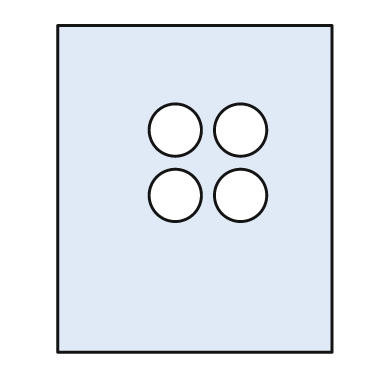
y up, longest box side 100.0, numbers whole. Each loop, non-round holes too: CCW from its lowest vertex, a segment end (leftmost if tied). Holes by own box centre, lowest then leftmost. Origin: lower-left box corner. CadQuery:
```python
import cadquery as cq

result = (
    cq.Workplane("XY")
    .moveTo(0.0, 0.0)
    .lineTo(84.0, 0.0)
    .lineTo(84.0, 100.0)
    .lineTo(0.0, 100.0)
    .close()
    .moveTo(36.0, 48.0)
    .circle(8.0)
    .moveTo(56.0, 48.0)
    .circle(8.0)
    .moveTo(36.0, 68.0)
    .circle(8.0)
    .moveTo(56.0, 68.0)
    .circle(8.0)
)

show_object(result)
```